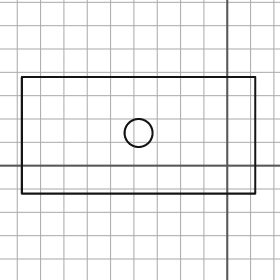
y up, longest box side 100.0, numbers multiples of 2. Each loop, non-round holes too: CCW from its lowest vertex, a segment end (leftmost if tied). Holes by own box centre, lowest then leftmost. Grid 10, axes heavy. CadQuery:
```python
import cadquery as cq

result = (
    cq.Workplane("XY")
    .moveTo(-88.0, -12.0)
    .lineTo(12.0, -12.0)
    .lineTo(12.0, 38.0)
    .lineTo(-88.0, 38.0)
    .close()
    .moveTo(-38.0, 14.0)
    .circle(6.0)
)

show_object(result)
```